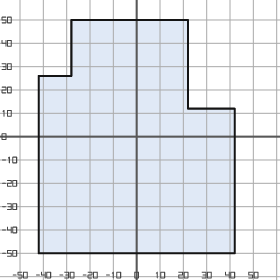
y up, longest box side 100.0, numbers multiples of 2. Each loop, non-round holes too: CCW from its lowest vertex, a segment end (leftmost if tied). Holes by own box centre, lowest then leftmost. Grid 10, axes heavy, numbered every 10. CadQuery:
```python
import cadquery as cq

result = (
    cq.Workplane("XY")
    .moveTo(-42.0, -50.0)
    .lineTo(42.0, -50.0)
    .lineTo(42.0, 12.0)
    .lineTo(22.0, 12.0)
    .lineTo(22.0, 50.0)
    .lineTo(-28.0, 50.0)
    .lineTo(-28.0, 26.0)
    .lineTo(-42.0, 26.0)
    .close()
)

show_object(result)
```